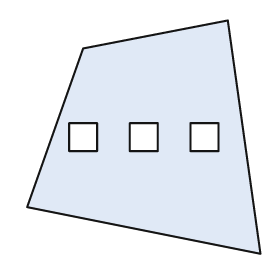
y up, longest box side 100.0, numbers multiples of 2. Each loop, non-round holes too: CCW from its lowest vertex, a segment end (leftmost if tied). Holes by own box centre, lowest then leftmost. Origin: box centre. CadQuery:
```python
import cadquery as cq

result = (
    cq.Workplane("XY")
    .moveTo(50.0, -50.0)
    .lineTo(36.0, 50.0)
    .lineTo(-26.0, 38.0)
    .lineTo(-50.0, -30.0)
    .close()
    .moveTo(-32.0, -6.0)
    .lineTo(-20.0, -6.0)
    .lineTo(-20.0, 6.0)
    .lineTo(-32.0, 6.0)
    .close()
    .moveTo(-6.0, -6.0)
    .lineTo(6.0, -6.0)
    .lineTo(6.0, 6.0)
    .lineTo(-6.0, 6.0)
    .close()
    .moveTo(20.0, -6.0)
    .lineTo(32.0, -6.0)
    .lineTo(32.0, 6.0)
    .lineTo(20.0, 6.0)
    .close()
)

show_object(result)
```